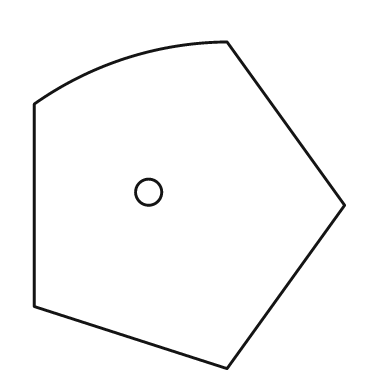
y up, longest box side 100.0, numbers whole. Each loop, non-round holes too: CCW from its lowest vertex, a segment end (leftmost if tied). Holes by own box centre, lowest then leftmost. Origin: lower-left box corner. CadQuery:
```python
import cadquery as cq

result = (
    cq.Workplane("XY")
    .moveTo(59.0, 0.0)
    .lineTo(95.0, 50.0)
    .lineTo(59.0, 100.0)
    .threePointArc((28.0, 95.0), (0.0, 81.0))
    .lineTo(0.0, 19.0)
    .close()
    .moveTo(35.0, 54.0)
    .circle(4.0)
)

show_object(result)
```